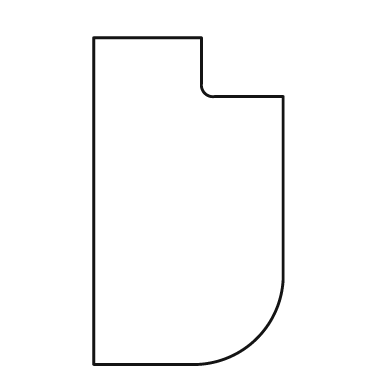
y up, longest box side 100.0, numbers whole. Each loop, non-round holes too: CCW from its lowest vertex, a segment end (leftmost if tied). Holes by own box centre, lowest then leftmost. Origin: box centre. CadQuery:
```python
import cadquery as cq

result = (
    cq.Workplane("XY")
    .moveTo(-29.0, -50.0)
    .lineTo(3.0, -50.0)
    .threePointArc((21.0, -42.0), (29.0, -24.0))
    .lineTo(29.0, 32.0)
    .lineTo(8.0, 32.0)
    .threePointArc((5.0, 33.0), (4.0, 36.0))
    .lineTo(4.0, 50.0)
    .lineTo(-29.0, 50.0)
    .close()
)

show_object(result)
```